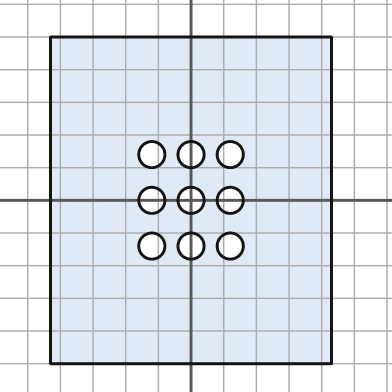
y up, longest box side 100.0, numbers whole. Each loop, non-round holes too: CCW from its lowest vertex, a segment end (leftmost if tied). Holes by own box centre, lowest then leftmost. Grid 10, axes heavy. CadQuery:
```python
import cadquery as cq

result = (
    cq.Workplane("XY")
    .moveTo(-43.0, -50.0)
    .lineTo(43.0, -50.0)
    .lineTo(43.0, 50.0)
    .lineTo(-43.0, 50.0)
    .close()
    .moveTo(-12.0, -14.0)
    .circle(4.0)
    .moveTo(0.0, -14.0)
    .circle(4.0)
    .moveTo(12.0, -14.0)
    .circle(4.0)
    .moveTo(-12.0, 0.0)
    .circle(4.0)
    .moveTo(0.0, 0.0)
    .circle(4.0)
    .moveTo(12.0, 0.0)
    .circle(4.0)
    .moveTo(-12.0, 14.0)
    .circle(4.0)
    .moveTo(0.0, 14.0)
    .circle(4.0)
    .moveTo(12.0, 14.0)
    .circle(4.0)
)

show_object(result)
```